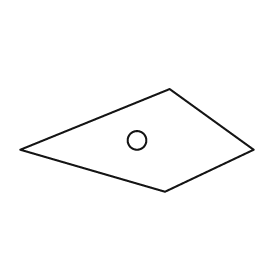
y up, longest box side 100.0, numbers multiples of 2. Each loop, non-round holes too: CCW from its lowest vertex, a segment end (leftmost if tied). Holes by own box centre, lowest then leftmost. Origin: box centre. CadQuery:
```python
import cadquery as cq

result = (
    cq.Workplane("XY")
    .moveTo(12.0, -22.0)
    .lineTo(50.0, -4.0)
    .lineTo(14.0, 22.0)
    .lineTo(-50.0, -4.0)
    .close()
    .moveTo(0.0, 0.0)
    .circle(4.0)
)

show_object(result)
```